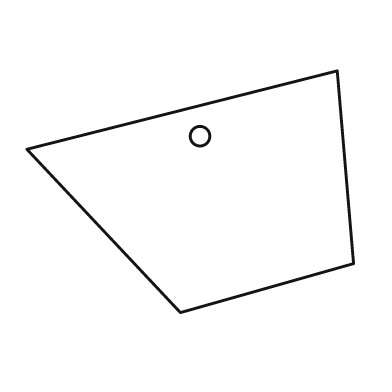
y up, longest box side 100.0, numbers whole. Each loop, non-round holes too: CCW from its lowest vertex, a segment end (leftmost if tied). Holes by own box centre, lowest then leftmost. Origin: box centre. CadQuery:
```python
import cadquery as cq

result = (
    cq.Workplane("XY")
    .moveTo(-3.0, -37.0)
    .lineTo(50.0, -22.0)
    .lineTo(45.0, 37.0)
    .lineTo(-50.0, 13.0)
    .close()
    .moveTo(3.0, 17.0)
    .circle(3.0)
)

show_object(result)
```